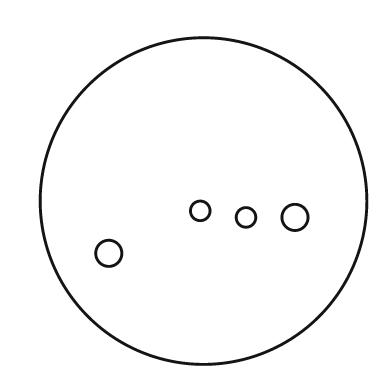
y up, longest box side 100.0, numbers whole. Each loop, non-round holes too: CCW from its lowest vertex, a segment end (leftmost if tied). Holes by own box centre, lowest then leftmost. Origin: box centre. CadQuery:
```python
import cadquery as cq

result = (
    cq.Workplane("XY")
    .moveTo(0.0, 0.0)
    .circle(50.0)
    .moveTo(-29.0, -16.0)
    .circle(4.0)
    .moveTo(13.0, -5.0)
    .circle(3.0)
    .moveTo(28.0, -5.0)
    .circle(4.0)
    .moveTo(-1.0, -3.0)
    .circle(3.0)
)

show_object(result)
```